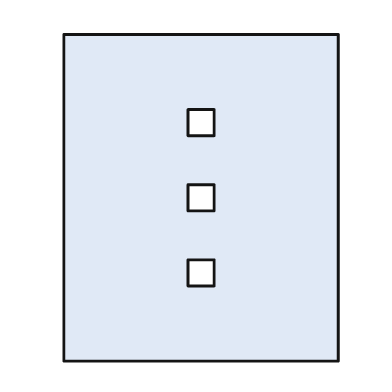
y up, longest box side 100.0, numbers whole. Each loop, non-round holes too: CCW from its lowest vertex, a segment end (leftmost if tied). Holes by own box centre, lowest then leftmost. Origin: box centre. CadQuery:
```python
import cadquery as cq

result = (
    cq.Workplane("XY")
    .moveTo(-42.0, -50.0)
    .lineTo(42.0, -50.0)
    .lineTo(42.0, 50.0)
    .lineTo(-42.0, 50.0)
    .close()
    .moveTo(-4.0, -27.0)
    .lineTo(4.0, -27.0)
    .lineTo(4.0, -19.0)
    .lineTo(-4.0, -19.0)
    .close()
    .moveTo(-4.0, -4.0)
    .lineTo(4.0, -4.0)
    .lineTo(4.0, 4.0)
    .lineTo(-4.0, 4.0)
    .close()
    .moveTo(-4.0, 19.0)
    .lineTo(4.0, 19.0)
    .lineTo(4.0, 27.0)
    .lineTo(-4.0, 27.0)
    .close()
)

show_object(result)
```